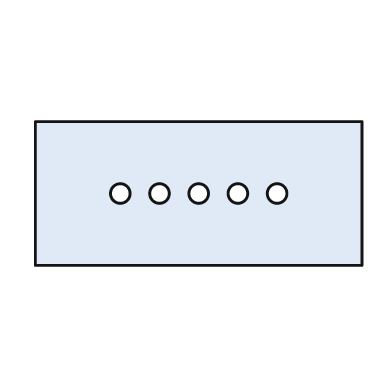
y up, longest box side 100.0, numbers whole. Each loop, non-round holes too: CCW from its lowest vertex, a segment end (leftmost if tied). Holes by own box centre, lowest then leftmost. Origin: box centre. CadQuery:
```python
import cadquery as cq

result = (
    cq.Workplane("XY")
    .moveTo(-50.0, -22.0)
    .lineTo(50.0, -22.0)
    .lineTo(50.0, 22.0)
    .lineTo(-50.0, 22.0)
    .close()
    .moveTo(-24.0, 0.0)
    .circle(3.0)
    .moveTo(-12.0, 0.0)
    .circle(3.0)
    .moveTo(0.0, 0.0)
    .circle(3.0)
    .moveTo(12.0, 0.0)
    .circle(3.0)
    .moveTo(24.0, 0.0)
    .circle(3.0)
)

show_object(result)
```